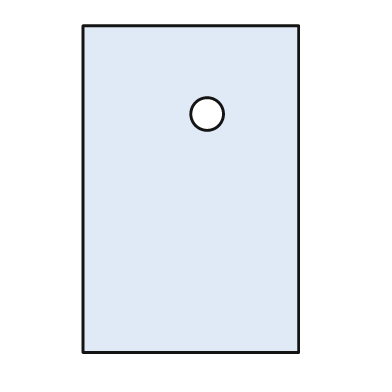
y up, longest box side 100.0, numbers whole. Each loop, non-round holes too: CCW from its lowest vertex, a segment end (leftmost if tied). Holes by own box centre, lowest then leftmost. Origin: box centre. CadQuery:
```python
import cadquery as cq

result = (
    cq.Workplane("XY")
    .moveTo(-33.0, -50.0)
    .lineTo(33.0, -50.0)
    .lineTo(33.0, 50.0)
    .lineTo(-33.0, 50.0)
    .close()
    .moveTo(5.0, 23.0)
    .circle(5.0)
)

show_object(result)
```